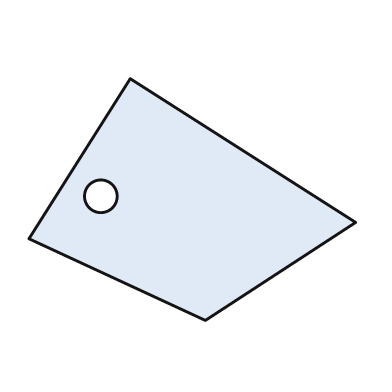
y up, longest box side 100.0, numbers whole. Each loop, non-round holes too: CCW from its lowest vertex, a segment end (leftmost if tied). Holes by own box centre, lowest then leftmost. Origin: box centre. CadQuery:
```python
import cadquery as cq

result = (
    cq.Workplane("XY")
    .moveTo(4.0, -37.0)
    .lineTo(50.0, -7.0)
    .lineTo(-19.0, 37.0)
    .lineTo(-50.0, -12.0)
    .close()
    .moveTo(-28.0, 1.0)
    .circle(5.0)
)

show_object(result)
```